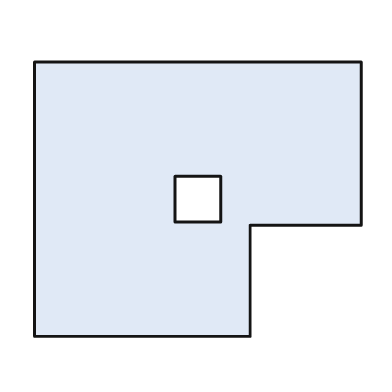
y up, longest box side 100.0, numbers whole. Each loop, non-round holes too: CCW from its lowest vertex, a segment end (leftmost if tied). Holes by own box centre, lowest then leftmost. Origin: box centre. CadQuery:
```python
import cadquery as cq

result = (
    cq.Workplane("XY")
    .moveTo(-50.0, -42.0)
    .lineTo(16.0, -42.0)
    .lineTo(16.0, -8.0)
    .lineTo(50.0, -8.0)
    .lineTo(50.0, 42.0)
    .lineTo(-50.0, 42.0)
    .close()
    .moveTo(-7.0, -7.0)
    .lineTo(7.0, -7.0)
    .lineTo(7.0, 7.0)
    .lineTo(-7.0, 7.0)
    .close()
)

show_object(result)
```